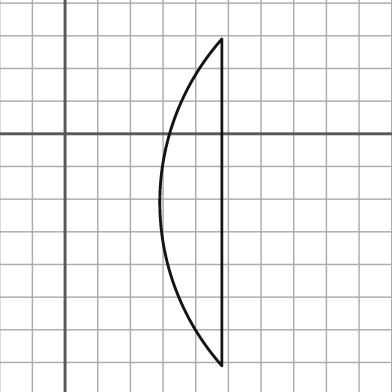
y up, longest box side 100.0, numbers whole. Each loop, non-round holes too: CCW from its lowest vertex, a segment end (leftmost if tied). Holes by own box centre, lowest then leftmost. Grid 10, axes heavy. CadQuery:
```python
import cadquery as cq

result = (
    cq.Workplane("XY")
    .moveTo(48.0, -71.0)
    .lineTo(48.0, 29.0)
    .threePointArc((29.0, -21.0), (48.0, -71.0))
    .close()
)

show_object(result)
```